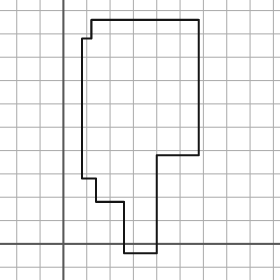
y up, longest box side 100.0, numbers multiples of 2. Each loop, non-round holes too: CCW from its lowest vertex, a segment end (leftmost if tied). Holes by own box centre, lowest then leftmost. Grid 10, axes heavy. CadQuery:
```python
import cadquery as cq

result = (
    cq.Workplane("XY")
    .moveTo(26.0, -4.0)
    .lineTo(40.0, -4.0)
    .lineTo(40.0, 38.0)
    .lineTo(58.0, 38.0)
    .lineTo(58.0, 96.0)
    .lineTo(12.0, 96.0)
    .lineTo(12.0, 88.0)
    .lineTo(8.0, 88.0)
    .lineTo(8.0, 28.0)
    .lineTo(14.0, 28.0)
    .lineTo(14.0, 18.0)
    .lineTo(26.0, 18.0)
    .close()
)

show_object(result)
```